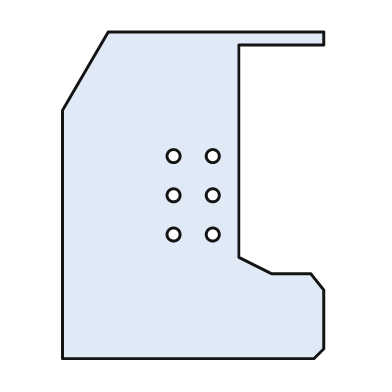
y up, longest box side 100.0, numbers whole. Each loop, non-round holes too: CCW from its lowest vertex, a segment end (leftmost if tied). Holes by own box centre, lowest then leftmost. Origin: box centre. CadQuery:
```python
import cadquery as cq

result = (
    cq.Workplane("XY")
    .moveTo(-40.0, -50.0)
    .lineTo(37.0, -50.0)
    .lineTo(40.0, -47.0)
    .lineTo(40.0, -29.0)
    .lineTo(36.0, -24.0)
    .lineTo(24.0, -24.0)
    .lineTo(14.0, -19.0)
    .lineTo(14.0, 46.0)
    .lineTo(40.0, 46.0)
    .lineTo(40.0, 50.0)
    .lineTo(-26.0, 50.0)
    .lineTo(-40.0, 26.0)
    .close()
    .moveTo(-6.0, -12.0)
    .circle(2.0)
    .moveTo(6.0, -12.0)
    .circle(2.0)
    .moveTo(-6.0, 0.0)
    .circle(2.0)
    .moveTo(6.0, 0.0)
    .circle(2.0)
    .moveTo(-6.0, 12.0)
    .circle(2.0)
    .moveTo(6.0, 12.0)
    .circle(2.0)
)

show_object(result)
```